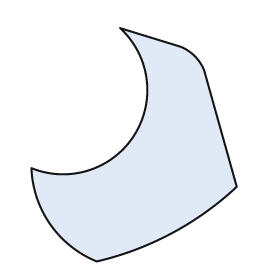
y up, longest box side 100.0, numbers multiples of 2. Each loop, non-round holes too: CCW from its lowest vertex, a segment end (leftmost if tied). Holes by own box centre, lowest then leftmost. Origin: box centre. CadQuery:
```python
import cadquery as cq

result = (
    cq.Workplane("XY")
    .moveTo(-16.0, -50.0)
    .threePointArc((16.0, -38.0), (44.0, -18.0))
    .lineTo(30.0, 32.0)
    .threePointArc((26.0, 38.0), (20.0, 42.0))
    .lineTo(-6.0, 50.0)
    .threePointArc((0.0, 4.0), (-44.0, -10.0))
    .threePointArc((-36.0, -34.0), (-16.0, -50.0))
    .close()
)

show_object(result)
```